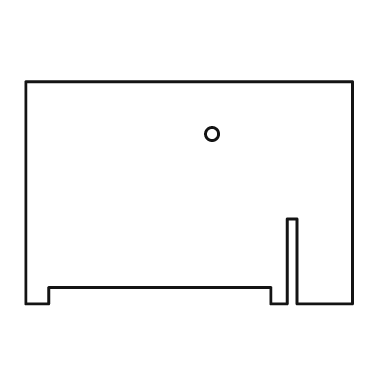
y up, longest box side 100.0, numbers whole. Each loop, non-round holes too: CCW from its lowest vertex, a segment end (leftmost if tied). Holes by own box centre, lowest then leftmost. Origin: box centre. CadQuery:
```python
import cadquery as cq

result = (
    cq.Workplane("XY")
    .moveTo(-50.0, -34.0)
    .lineTo(-43.0, -34.0)
    .lineTo(-43.0, -29.0)
    .lineTo(25.0, -29.0)
    .lineTo(25.0, -34.0)
    .lineTo(30.0, -34.0)
    .lineTo(30.0, -8.0)
    .lineTo(33.0, -8.0)
    .lineTo(33.0, -34.0)
    .lineTo(50.0, -34.0)
    .lineTo(50.0, 34.0)
    .lineTo(-50.0, 34.0)
    .close()
    .moveTo(7.0, 18.0)
    .circle(2.0)
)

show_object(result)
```